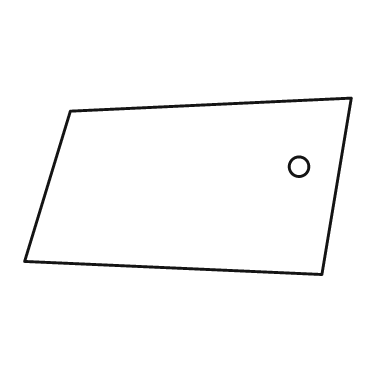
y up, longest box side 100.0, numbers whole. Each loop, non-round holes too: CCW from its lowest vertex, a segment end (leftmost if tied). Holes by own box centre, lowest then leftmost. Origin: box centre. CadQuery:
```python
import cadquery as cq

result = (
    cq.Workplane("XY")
    .moveTo(41.0, -27.0)
    .lineTo(50.0, 27.0)
    .lineTo(-36.0, 23.0)
    .lineTo(-50.0, -23.0)
    .close()
    .moveTo(34.0, 6.0)
    .circle(3.0)
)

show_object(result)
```